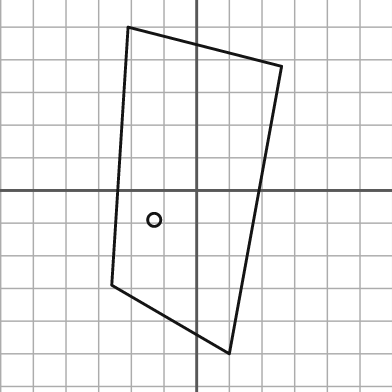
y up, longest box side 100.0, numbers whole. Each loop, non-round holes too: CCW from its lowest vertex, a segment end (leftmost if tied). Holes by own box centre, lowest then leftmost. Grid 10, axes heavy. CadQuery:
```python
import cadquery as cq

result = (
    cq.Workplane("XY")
    .moveTo(10.0, -50.0)
    .lineTo(26.0, 38.0)
    .lineTo(-21.0, 50.0)
    .lineTo(-26.0, -29.0)
    .close()
    .moveTo(-13.0, -9.0)
    .circle(2.0)
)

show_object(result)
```